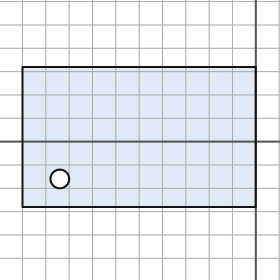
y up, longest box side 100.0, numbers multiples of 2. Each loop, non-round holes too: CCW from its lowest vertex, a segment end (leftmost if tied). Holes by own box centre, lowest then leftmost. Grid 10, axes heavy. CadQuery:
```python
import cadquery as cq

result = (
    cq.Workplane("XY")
    .moveTo(-100.0, -28.0)
    .lineTo(0.0, -28.0)
    .lineTo(0.0, 32.0)
    .lineTo(-100.0, 32.0)
    .close()
    .moveTo(-84.0, -16.0)
    .circle(4.0)
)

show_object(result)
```